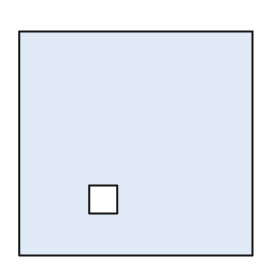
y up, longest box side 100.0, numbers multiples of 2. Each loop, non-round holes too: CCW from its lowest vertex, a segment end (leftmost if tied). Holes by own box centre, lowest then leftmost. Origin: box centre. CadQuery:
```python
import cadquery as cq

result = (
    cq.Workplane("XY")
    .moveTo(-50.0, -48.0)
    .lineTo(50.0, -48.0)
    .lineTo(50.0, 48.0)
    .lineTo(-50.0, 48.0)
    .close()
    .moveTo(-20.0, -30.0)
    .lineTo(-8.0, -30.0)
    .lineTo(-8.0, -18.0)
    .lineTo(-20.0, -18.0)
    .close()
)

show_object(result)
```